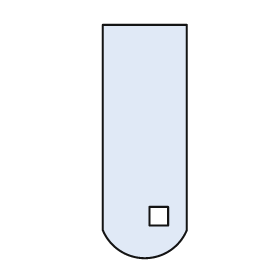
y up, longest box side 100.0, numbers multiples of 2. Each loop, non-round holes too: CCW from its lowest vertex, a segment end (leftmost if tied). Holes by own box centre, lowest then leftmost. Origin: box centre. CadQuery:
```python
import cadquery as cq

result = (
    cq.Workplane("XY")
    .moveTo(-18.0, -38.0)
    .threePointArc((0.0, -50.0), (18.0, -38.0))
    .lineTo(18.0, 50.0)
    .lineTo(-18.0, 50.0)
    .close()
    .moveTo(2.0, -36.0)
    .lineTo(10.0, -36.0)
    .lineTo(10.0, -28.0)
    .lineTo(2.0, -28.0)
    .close()
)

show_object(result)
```